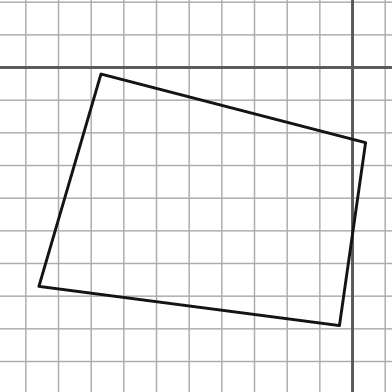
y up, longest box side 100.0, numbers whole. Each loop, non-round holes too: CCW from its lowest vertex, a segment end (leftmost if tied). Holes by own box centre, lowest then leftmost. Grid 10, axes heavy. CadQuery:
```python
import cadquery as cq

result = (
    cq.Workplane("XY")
    .moveTo(-4.0, -79.0)
    .lineTo(4.0, -23.0)
    .lineTo(-77.0, -2.0)
    .lineTo(-96.0, -67.0)
    .close()
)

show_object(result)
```